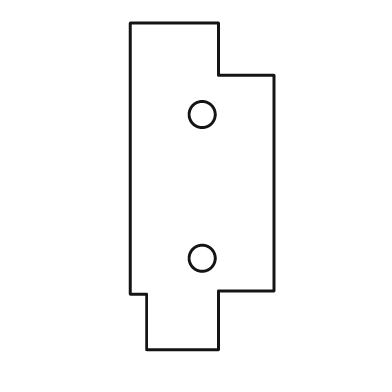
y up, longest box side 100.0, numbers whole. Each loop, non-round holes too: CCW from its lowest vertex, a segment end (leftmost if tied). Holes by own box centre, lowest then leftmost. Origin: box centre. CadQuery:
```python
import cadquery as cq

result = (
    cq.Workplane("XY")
    .moveTo(-17.0, -50.0)
    .lineTo(5.0, -50.0)
    .lineTo(5.0, -32.0)
    .lineTo(22.0, -32.0)
    .lineTo(22.0, 34.0)
    .lineTo(5.0, 34.0)
    .lineTo(5.0, 50.0)
    .lineTo(-22.0, 50.0)
    .lineTo(-22.0, -33.0)
    .lineTo(-17.0, -33.0)
    .close()
    .moveTo(0.0, -22.0)
    .circle(4.0)
    .moveTo(0.0, 22.0)
    .circle(4.0)
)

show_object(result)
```